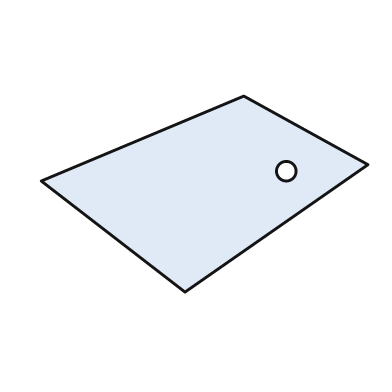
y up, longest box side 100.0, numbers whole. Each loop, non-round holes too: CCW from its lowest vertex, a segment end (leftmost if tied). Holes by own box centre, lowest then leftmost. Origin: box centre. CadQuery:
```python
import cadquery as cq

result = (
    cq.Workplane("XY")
    .moveTo(-6.0, -30.0)
    .lineTo(50.0, 9.0)
    .lineTo(12.0, 30.0)
    .lineTo(-50.0, 4.0)
    .close()
    .moveTo(25.0, 7.0)
    .circle(3.0)
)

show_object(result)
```